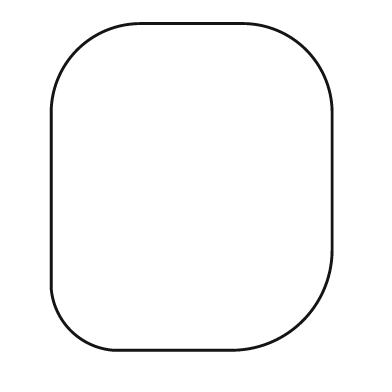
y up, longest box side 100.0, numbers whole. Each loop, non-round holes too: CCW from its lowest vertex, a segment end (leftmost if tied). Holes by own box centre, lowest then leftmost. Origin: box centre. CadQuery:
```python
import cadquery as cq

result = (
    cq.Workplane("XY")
    .moveTo(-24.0, -50.0)
    .lineTo(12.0, -50.0)
    .threePointArc((34.0, -41.0), (43.0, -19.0))
    .lineTo(43.0, 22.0)
    .threePointArc((35.0, 42.0), (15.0, 50.0))
    .lineTo(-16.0, 50.0)
    .threePointArc((-35.0, 42.0), (-43.0, 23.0))
    .lineTo(-43.0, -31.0)
    .threePointArc((-37.0, -44.0), (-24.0, -50.0))
    .close()
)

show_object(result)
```